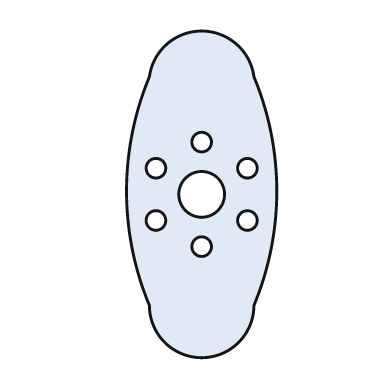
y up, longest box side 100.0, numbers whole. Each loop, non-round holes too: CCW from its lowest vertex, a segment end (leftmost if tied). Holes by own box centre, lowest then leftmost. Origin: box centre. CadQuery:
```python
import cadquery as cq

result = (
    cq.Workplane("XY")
    .moveTo(-16.0, -34.0)
    .threePointArc((0.0, -50.0), (16.0, -34.0))
    .threePointArc((23.0, 1.0), (16.0, 36.0))
    .threePointArc((0.0, 50.0), (-16.0, 36.0))
    .threePointArc((-23.0, 1.0), (-16.0, -34.0))
    .close()
    .moveTo(0.0, -16.0)
    .circle(3.0)
    .moveTo(-14.0, -8.0)
    .circle(3.0)
    .moveTo(14.0, -8.0)
    .circle(3.0)
    .moveTo(0.0, 0.0)
    .circle(7.0)
    .moveTo(-14.0, 8.0)
    .circle(3.0)
    .moveTo(14.0, 8.0)
    .circle(3.0)
    .moveTo(0.0, 16.0)
    .circle(3.0)
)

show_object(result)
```